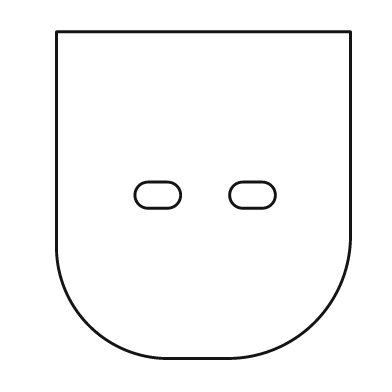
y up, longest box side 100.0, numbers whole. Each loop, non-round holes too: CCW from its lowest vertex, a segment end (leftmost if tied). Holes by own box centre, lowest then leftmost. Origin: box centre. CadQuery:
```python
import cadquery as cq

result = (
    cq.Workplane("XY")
    .moveTo(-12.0, -50.0)
    .lineTo(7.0, -50.0)
    .threePointArc((34.0, -39.0), (45.0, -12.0))
    .lineTo(45.0, 50.0)
    .lineTo(-45.0, 50.0)
    .lineTo(-45.0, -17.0)
    .threePointArc((-35.0, -40.0), (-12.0, -50.0))
    .close()
    .moveTo(-17.0, -4.0)
    .lineTo(-11.0, -4.0)
    .threePointArc((-7.0, 0.0), (-11.0, 4.0))
    .lineTo(-17.0, 4.0)
    .threePointArc((-21.0, 0.0), (-17.0, -4.0))
    .close()
    .moveTo(12.0, -4.0)
    .lineTo(18.0, -4.0)
    .threePointArc((22.0, 0.0), (18.0, 4.0))
    .lineTo(12.0, 4.0)
    .threePointArc((8.0, 0.0), (12.0, -4.0))
    .close()
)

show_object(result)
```